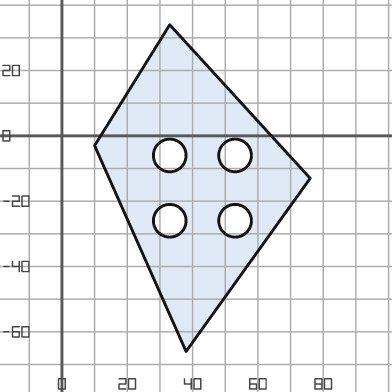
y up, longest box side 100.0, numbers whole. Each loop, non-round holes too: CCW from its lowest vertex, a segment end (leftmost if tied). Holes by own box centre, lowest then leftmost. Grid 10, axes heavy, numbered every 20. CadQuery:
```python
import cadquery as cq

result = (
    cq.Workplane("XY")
    .moveTo(38.0, -66.0)
    .lineTo(76.0, -13.0)
    .lineTo(33.0, 34.0)
    .lineTo(10.0, -3.0)
    .close()
    .moveTo(33.0, -26.0)
    .circle(5.0)
    .moveTo(53.0, -26.0)
    .circle(5.0)
    .moveTo(33.0, -6.0)
    .circle(5.0)
    .moveTo(53.0, -6.0)
    .circle(5.0)
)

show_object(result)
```